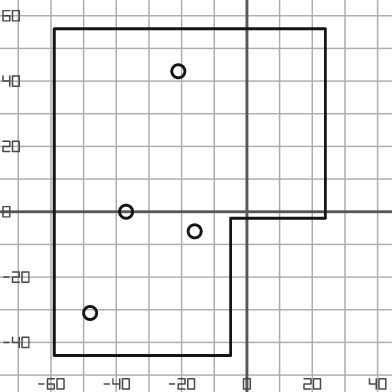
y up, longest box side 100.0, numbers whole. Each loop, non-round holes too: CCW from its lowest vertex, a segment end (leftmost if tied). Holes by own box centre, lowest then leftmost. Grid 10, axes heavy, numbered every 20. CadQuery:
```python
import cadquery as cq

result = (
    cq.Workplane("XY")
    .moveTo(-59.0, -44.0)
    .lineTo(-5.0, -44.0)
    .lineTo(-5.0, -2.0)
    .lineTo(24.0, -2.0)
    .lineTo(24.0, 56.0)
    .lineTo(-59.0, 56.0)
    .close()
    .moveTo(-48.0, -31.0)
    .circle(2.0)
    .moveTo(-16.0, -6.0)
    .circle(2.0)
    .moveTo(-37.0, 0.0)
    .circle(2.0)
    .moveTo(-21.0, 43.0)
    .circle(2.0)
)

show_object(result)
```